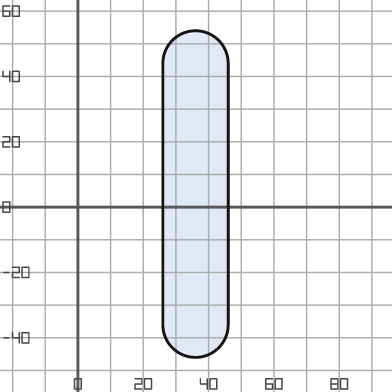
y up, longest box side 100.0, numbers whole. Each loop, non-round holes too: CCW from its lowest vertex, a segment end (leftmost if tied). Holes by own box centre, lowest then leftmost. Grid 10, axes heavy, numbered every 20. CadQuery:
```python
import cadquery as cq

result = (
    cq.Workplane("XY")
    .moveTo(26.0, -36.0)
    .threePointArc((36.0, -46.0), (46.0, -36.0))
    .lineTo(46.0, 44.0)
    .threePointArc((36.0, 54.0), (26.0, 44.0))
    .close()
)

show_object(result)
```